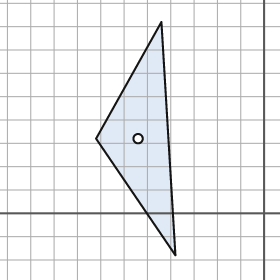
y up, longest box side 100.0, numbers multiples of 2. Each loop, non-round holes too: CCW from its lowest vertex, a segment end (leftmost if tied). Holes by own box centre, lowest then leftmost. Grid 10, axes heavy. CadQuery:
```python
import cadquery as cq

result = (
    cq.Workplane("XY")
    .moveTo(-38.0, -18.0)
    .lineTo(-44.0, 82.0)
    .lineTo(-72.0, 32.0)
    .close()
    .moveTo(-54.0, 32.0)
    .circle(2.0)
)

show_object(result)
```